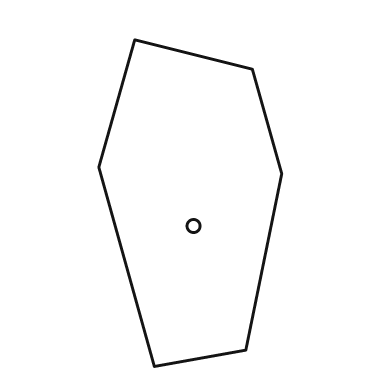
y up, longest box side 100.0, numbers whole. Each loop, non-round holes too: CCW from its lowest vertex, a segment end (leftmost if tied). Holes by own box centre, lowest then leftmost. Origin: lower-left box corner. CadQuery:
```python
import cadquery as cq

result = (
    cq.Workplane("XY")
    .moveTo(17.0, 0.0)
    .lineTo(45.0, 5.0)
    .lineTo(56.0, 59.0)
    .lineTo(47.0, 91.0)
    .lineTo(11.0, 100.0)
    .lineTo(0.0, 61.0)
    .close()
    .moveTo(29.0, 43.0)
    .circle(2.0)
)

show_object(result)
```